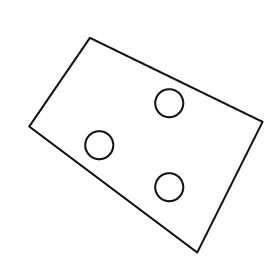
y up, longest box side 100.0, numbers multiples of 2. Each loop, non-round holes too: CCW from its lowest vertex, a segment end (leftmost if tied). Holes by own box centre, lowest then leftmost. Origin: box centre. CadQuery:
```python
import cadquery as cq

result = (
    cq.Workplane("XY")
    .moveTo(22.0, -46.0)
    .lineTo(50.0, 10.0)
    .lineTo(-24.0, 46.0)
    .lineTo(-50.0, 8.0)
    .close()
    .moveTo(10.0, -18.0)
    .circle(6.0)
    .moveTo(-20.0, 0.0)
    .circle(6.0)
    .moveTo(10.0, 18.0)
    .circle(6.0)
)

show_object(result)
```